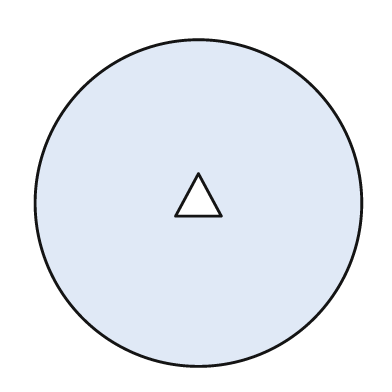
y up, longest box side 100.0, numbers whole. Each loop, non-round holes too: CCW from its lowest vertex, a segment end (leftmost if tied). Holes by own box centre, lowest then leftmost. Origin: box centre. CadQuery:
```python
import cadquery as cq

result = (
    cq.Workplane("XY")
    .moveTo(0.0, 0.0)
    .circle(50.0)
    .moveTo(-7.0, -4.0)
    .lineTo(7.0, -4.0)
    .lineTo(0.0, 9.0)
    .close()
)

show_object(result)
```